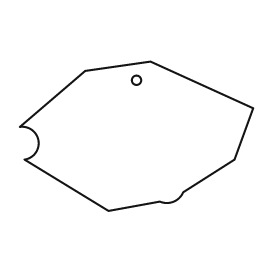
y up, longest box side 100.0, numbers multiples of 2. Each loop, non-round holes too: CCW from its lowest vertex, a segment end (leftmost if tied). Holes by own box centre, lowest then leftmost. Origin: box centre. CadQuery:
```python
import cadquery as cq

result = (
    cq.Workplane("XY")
    .moveTo(-12.0, -32.0)
    .lineTo(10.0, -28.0)
    .threePointArc((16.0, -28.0), (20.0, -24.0))
    .lineTo(42.0, -10.0)
    .lineTo(50.0, 12.0)
    .lineTo(6.0, 32.0)
    .lineTo(-22.0, 28.0)
    .lineTo(-50.0, 4.0)
    .threePointArc((-42.0, -2.0), (-48.0, -10.0))
    .close()
    .moveTo(0.0, 24.0)
    .circle(2.0)
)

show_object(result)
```